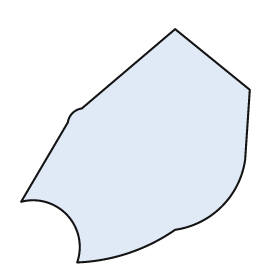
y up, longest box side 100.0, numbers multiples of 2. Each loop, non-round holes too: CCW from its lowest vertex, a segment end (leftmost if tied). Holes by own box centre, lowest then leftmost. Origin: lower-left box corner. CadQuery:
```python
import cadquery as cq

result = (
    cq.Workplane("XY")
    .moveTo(24.0, 0.0)
    .threePointArc((46.0, 4.0), (66.0, 14.0))
    .threePointArc((86.0, 24.0), (96.0, 44.0))
    .lineTo(98.0, 74.0)
    .lineTo(66.0, 100.0)
    .lineTo(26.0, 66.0)
    .threePointArc((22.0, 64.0), (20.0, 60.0))
    .lineTo(0.0, 26.0)
    .threePointArc((20.0, 20.0), (24.0, 0.0))
    .close()
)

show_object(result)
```